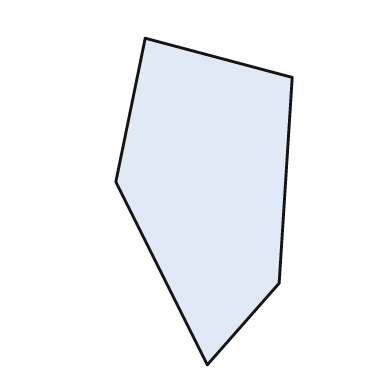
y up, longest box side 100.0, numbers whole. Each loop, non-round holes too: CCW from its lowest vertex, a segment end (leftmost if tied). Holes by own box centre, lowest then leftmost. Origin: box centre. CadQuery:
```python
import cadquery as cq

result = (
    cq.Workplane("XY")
    .moveTo(1.0, -50.0)
    .lineTo(23.0, -25.0)
    .lineTo(27.0, 38.0)
    .lineTo(-18.0, 50.0)
    .lineTo(-27.0, 6.0)
    .close()
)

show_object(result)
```